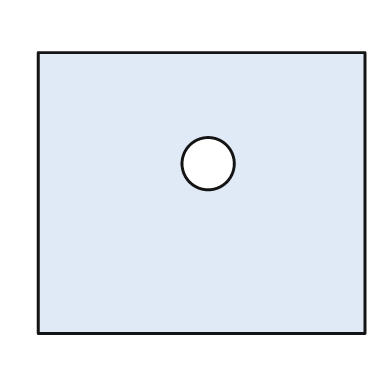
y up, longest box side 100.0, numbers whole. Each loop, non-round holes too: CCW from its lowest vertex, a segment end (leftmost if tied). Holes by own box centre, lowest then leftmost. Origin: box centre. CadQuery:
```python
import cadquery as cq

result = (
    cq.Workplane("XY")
    .moveTo(-50.0, -43.0)
    .lineTo(50.0, -43.0)
    .lineTo(50.0, 43.0)
    .lineTo(-50.0, 43.0)
    .close()
    .moveTo(2.0, 9.0)
    .circle(8.0)
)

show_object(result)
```